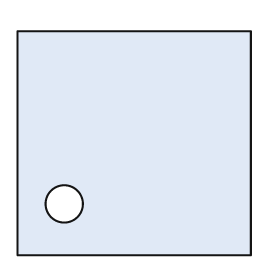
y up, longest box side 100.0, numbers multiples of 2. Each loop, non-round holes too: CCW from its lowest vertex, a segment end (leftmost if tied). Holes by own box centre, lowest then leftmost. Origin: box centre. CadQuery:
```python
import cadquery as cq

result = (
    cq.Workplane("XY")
    .moveTo(-50.0, -48.0)
    .lineTo(50.0, -48.0)
    .lineTo(50.0, 48.0)
    .lineTo(-50.0, 48.0)
    .close()
    .moveTo(-30.0, -26.0)
    .circle(8.0)
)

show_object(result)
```